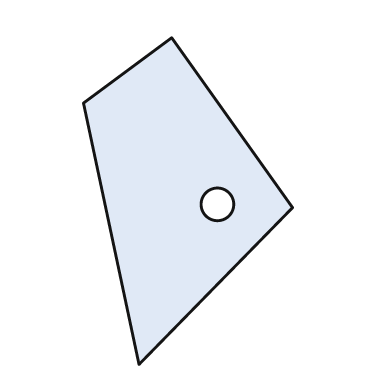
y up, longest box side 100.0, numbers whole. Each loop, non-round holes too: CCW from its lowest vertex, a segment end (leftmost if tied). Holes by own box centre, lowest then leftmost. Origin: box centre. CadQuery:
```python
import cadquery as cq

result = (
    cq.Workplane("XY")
    .moveTo(-15.0, -50.0)
    .lineTo(32.0, -2.0)
    .lineTo(-5.0, 50.0)
    .lineTo(-32.0, 30.0)
    .close()
    .moveTo(9.0, -1.0)
    .circle(5.0)
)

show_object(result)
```